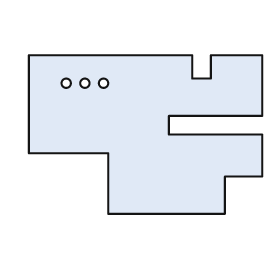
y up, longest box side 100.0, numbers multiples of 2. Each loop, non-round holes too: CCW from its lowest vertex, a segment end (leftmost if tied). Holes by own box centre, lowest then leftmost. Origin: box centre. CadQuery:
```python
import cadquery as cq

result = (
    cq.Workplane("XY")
    .moveTo(-16.0, -34.0)
    .lineTo(34.0, -34.0)
    .lineTo(34.0, -18.0)
    .lineTo(50.0, -18.0)
    .lineTo(50.0, 0.0)
    .lineTo(10.0, 0.0)
    .lineTo(10.0, 8.0)
    .lineTo(50.0, 8.0)
    .lineTo(50.0, 34.0)
    .lineTo(28.0, 34.0)
    .lineTo(28.0, 24.0)
    .lineTo(20.0, 24.0)
    .lineTo(20.0, 34.0)
    .lineTo(-50.0, 34.0)
    .lineTo(-50.0, -8.0)
    .lineTo(-16.0, -8.0)
    .close()
    .moveTo(-34.0, 22.0)
    .circle(2.0)
    .moveTo(-26.0, 22.0)
    .circle(2.0)
    .moveTo(-18.0, 22.0)
    .circle(2.0)
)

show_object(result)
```